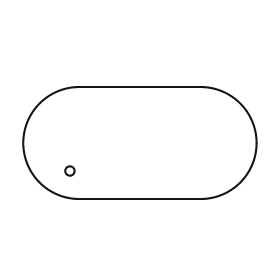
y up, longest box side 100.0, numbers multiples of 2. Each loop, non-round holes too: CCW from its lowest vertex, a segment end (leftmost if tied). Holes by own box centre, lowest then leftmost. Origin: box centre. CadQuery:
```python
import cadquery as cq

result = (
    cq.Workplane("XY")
    .moveTo(-26.0, -24.0)
    .lineTo(26.0, -24.0)
    .threePointArc((50.0, 0.0), (26.0, 24.0))
    .lineTo(-26.0, 24.0)
    .threePointArc((-50.0, 0.0), (-26.0, -24.0))
    .close()
    .moveTo(-30.0, -12.0)
    .circle(2.0)
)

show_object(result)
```